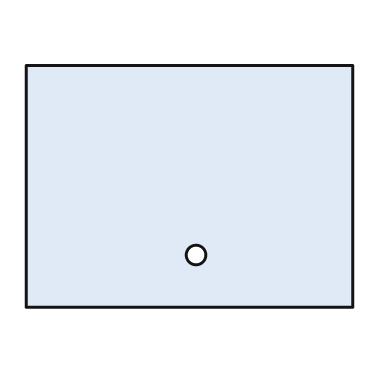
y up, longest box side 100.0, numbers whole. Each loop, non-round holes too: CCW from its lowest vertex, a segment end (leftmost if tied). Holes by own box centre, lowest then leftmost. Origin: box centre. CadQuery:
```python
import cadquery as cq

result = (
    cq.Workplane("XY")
    .moveTo(-50.0, -37.0)
    .lineTo(50.0, -37.0)
    .lineTo(50.0, 37.0)
    .lineTo(-50.0, 37.0)
    .close()
    .moveTo(2.0, -21.0)
    .circle(3.0)
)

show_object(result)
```